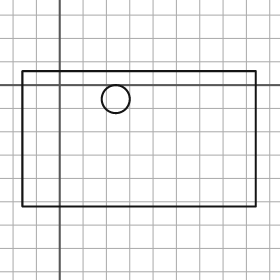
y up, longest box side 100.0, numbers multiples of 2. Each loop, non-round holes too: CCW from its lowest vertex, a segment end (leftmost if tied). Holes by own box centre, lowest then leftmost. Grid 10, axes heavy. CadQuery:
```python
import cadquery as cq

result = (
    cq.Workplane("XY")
    .moveTo(-16.0, -52.0)
    .lineTo(84.0, -52.0)
    .lineTo(84.0, 6.0)
    .lineTo(-16.0, 6.0)
    .close()
    .moveTo(24.0, -6.0)
    .circle(6.0)
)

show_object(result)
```